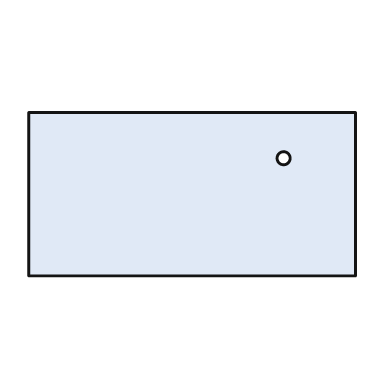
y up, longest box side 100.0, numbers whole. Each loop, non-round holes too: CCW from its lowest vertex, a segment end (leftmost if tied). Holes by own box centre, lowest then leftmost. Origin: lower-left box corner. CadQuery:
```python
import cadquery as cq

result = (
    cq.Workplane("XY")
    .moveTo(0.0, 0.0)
    .lineTo(100.0, 0.0)
    .lineTo(100.0, 50.0)
    .lineTo(0.0, 50.0)
    .close()
    .moveTo(78.0, 36.0)
    .circle(2.0)
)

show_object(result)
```